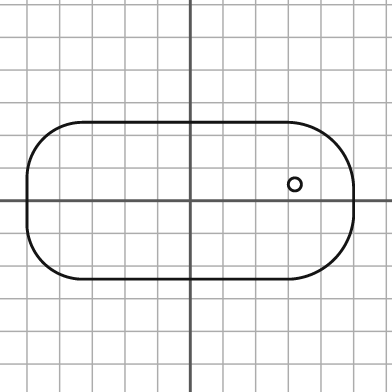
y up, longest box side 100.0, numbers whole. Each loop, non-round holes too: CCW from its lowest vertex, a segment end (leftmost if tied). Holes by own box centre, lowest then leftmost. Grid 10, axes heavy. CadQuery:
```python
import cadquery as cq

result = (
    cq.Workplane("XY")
    .moveTo(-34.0, -24.0)
    .lineTo(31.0, -24.0)
    .threePointArc((44.0, -18.0), (50.0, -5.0))
    .lineTo(50.0, 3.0)
    .threePointArc((44.0, 18.0), (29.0, 24.0))
    .lineTo(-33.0, 24.0)
    .threePointArc((-45.0, 19.0), (-50.0, 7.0))
    .lineTo(-50.0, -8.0)
    .threePointArc((-45.0, -19.0), (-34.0, -24.0))
    .close()
    .moveTo(32.0, 5.0)
    .circle(2.0)
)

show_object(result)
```